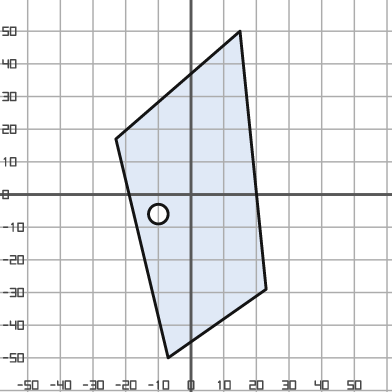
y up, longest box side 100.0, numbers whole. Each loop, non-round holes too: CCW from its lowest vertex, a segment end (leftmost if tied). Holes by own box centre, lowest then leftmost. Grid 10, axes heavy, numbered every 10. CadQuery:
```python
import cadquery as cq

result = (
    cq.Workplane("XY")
    .moveTo(-7.0, -50.0)
    .lineTo(23.0, -29.0)
    .lineTo(15.0, 50.0)
    .lineTo(-23.0, 17.0)
    .close()
    .moveTo(-10.0, -6.0)
    .circle(3.0)
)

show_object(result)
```